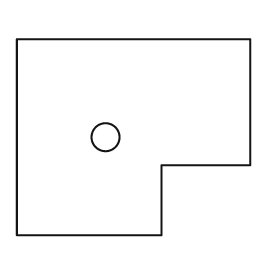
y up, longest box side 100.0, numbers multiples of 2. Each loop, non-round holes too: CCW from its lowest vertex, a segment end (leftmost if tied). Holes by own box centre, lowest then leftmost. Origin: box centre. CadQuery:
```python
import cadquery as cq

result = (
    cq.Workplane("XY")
    .moveTo(-50.0, -42.0)
    .lineTo(12.0, -42.0)
    .lineTo(12.0, -12.0)
    .lineTo(50.0, -12.0)
    .lineTo(50.0, 42.0)
    .lineTo(-50.0, 42.0)
    .close()
    .moveTo(-12.0, 0.0)
    .circle(6.0)
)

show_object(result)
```